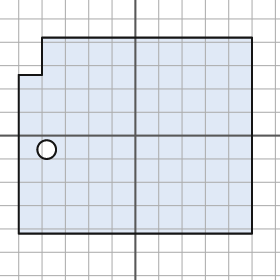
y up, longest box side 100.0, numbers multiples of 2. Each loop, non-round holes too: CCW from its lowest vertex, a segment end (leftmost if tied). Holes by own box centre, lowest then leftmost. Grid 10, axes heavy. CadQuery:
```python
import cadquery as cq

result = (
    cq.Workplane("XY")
    .moveTo(-50.0, -42.0)
    .lineTo(50.0, -42.0)
    .lineTo(50.0, 42.0)
    .lineTo(-40.0, 42.0)
    .lineTo(-40.0, 26.0)
    .lineTo(-50.0, 26.0)
    .close()
    .moveTo(-38.0, -6.0)
    .circle(4.0)
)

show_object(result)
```